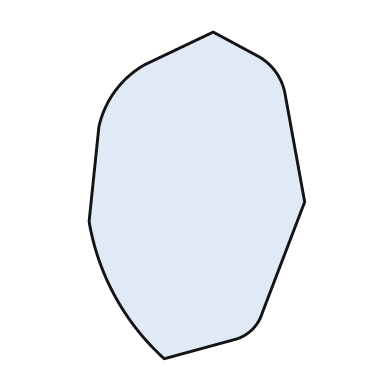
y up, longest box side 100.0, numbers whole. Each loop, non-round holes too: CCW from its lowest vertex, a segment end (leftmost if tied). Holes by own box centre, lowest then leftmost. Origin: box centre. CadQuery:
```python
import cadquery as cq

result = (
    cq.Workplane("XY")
    .moveTo(-10.0, -50.0)
    .lineTo(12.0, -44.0)
    .threePointArc((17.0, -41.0), (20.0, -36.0))
    .lineTo(33.0, -2.0)
    .lineTo(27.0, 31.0)
    .threePointArc((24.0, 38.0), (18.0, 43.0))
    .lineTo(5.0, 50.0)
    .lineTo(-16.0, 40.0)
    .threePointArc((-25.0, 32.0), (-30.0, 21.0))
    .lineTo(-33.0, -8.0)
    .threePointArc((-25.0, -31.0), (-10.0, -50.0))
    .close()
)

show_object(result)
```